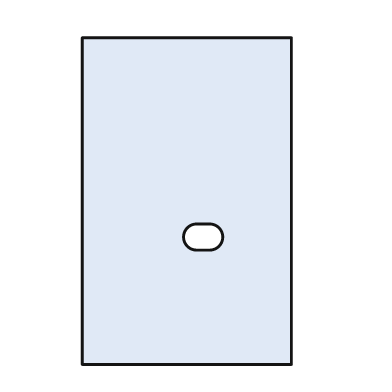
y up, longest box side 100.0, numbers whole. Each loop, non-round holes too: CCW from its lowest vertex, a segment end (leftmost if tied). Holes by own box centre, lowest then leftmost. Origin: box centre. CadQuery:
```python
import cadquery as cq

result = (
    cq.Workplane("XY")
    .moveTo(-32.0, -50.0)
    .lineTo(32.0, -50.0)
    .lineTo(32.0, 50.0)
    .lineTo(-32.0, 50.0)
    .close()
    .moveTo(3.0, -15.0)
    .lineTo(7.0, -15.0)
    .threePointArc((11.0, -11.0), (7.0, -7.0))
    .lineTo(3.0, -7.0)
    .threePointArc((-1.0, -11.0), (3.0, -15.0))
    .close()
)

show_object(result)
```